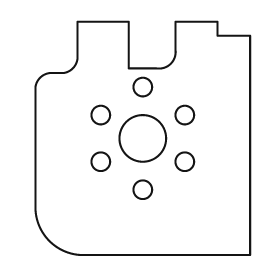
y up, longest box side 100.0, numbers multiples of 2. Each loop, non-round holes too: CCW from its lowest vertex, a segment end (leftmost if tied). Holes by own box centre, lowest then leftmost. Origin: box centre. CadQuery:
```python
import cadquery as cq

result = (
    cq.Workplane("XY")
    .moveTo(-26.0, -50.0)
    .lineTo(46.0, -50.0)
    .lineTo(46.0, 44.0)
    .lineTo(32.0, 44.0)
    .lineTo(32.0, 50.0)
    .lineTo(14.0, 50.0)
    .lineTo(14.0, 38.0)
    .threePointArc((12.0, 32.0), (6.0, 30.0))
    .lineTo(-6.0, 30.0)
    .lineTo(-6.0, 50.0)
    .lineTo(-28.0, 50.0)
    .lineTo(-28.0, 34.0)
    .threePointArc((-30.0, 30.0), (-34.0, 28.0))
    .lineTo(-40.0, 28.0)
    .threePointArc((-44.0, 26.0), (-46.0, 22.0))
    .lineTo(-46.0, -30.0)
    .threePointArc((-40.0, -44.0), (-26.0, -50.0))
    .close()
    .moveTo(0.0, -22.0)
    .circle(4.0)
    .moveTo(-18.0, -10.0)
    .circle(4.0)
    .moveTo(18.0, -10.0)
    .circle(4.0)
    .moveTo(0.0, 0.0)
    .circle(10.0)
    .moveTo(-18.0, 10.0)
    .circle(4.0)
    .moveTo(18.0, 10.0)
    .circle(4.0)
    .moveTo(0.0, 22.0)
    .circle(4.0)
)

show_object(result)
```